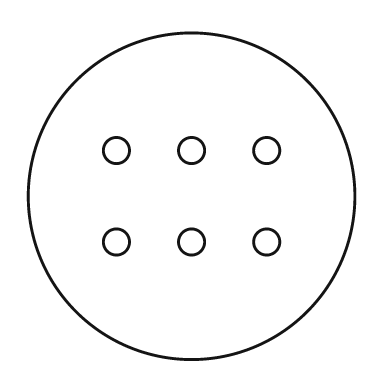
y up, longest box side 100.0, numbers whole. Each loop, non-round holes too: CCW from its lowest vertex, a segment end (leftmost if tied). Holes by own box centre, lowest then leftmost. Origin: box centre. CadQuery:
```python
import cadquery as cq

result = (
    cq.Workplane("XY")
    .moveTo(0.0, 0.0)
    .circle(50.0)
    .moveTo(-23.0, -14.0)
    .circle(4.0)
    .moveTo(0.0, -14.0)
    .circle(4.0)
    .moveTo(23.0, -14.0)
    .circle(4.0)
    .moveTo(-23.0, 14.0)
    .circle(4.0)
    .moveTo(0.0, 14.0)
    .circle(4.0)
    .moveTo(23.0, 14.0)
    .circle(4.0)
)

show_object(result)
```